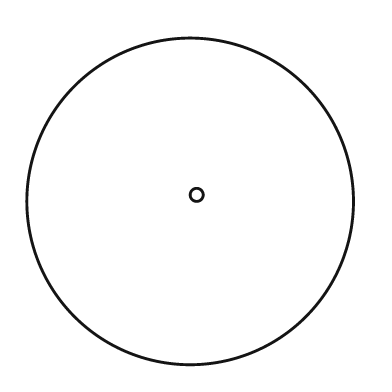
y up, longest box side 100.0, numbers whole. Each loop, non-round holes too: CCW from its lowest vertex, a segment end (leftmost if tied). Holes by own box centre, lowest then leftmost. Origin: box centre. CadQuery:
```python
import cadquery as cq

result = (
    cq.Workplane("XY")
    .moveTo(0.0, 0.0)
    .circle(50.0)
    .moveTo(2.0, 2.0)
    .circle(2.0)
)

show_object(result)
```